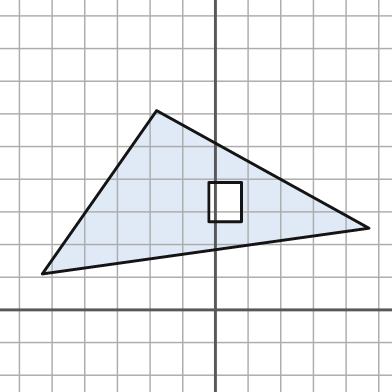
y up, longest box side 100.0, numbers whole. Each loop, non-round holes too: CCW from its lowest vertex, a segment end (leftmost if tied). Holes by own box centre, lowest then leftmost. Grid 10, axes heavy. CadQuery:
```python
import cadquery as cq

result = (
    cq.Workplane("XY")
    .moveTo(-53.0, 11.0)
    .lineTo(47.0, 25.0)
    .lineTo(-18.0, 61.0)
    .close()
    .moveTo(-2.0, 27.0)
    .lineTo(8.0, 27.0)
    .lineTo(8.0, 39.0)
    .lineTo(-2.0, 39.0)
    .close()
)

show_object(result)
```